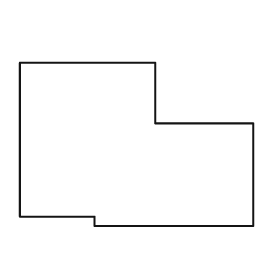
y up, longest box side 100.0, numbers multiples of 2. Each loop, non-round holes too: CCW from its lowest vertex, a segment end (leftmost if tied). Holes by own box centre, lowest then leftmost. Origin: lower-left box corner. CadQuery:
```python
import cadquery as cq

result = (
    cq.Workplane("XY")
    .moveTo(32.0, 0.0)
    .lineTo(100.0, 0.0)
    .lineTo(100.0, 44.0)
    .lineTo(58.0, 44.0)
    .lineTo(58.0, 70.0)
    .lineTo(0.0, 70.0)
    .lineTo(0.0, 4.0)
    .lineTo(32.0, 4.0)
    .close()
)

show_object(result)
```